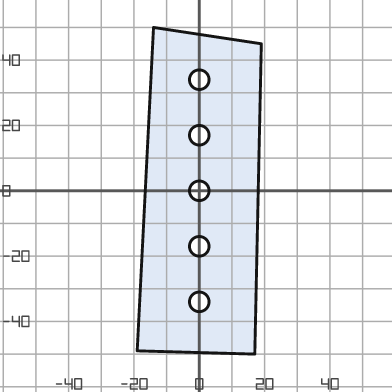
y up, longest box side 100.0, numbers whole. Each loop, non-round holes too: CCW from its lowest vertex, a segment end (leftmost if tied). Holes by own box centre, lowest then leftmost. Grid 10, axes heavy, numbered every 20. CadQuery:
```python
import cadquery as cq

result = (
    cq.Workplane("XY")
    .moveTo(17.0, -50.0)
    .lineTo(19.0, 45.0)
    .lineTo(-14.0, 50.0)
    .lineTo(-19.0, -49.0)
    .close()
    .moveTo(0.0, -34.0)
    .circle(3.0)
    .moveTo(0.0, -17.0)
    .circle(3.0)
    .moveTo(0.0, 0.0)
    .circle(3.0)
    .moveTo(0.0, 17.0)
    .circle(3.0)
    .moveTo(0.0, 34.0)
    .circle(3.0)
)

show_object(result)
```